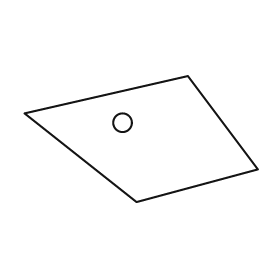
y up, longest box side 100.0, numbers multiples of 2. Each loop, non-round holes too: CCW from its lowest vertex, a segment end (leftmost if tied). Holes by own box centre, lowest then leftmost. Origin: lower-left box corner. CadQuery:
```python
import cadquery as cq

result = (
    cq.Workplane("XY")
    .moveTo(48.0, 0.0)
    .lineTo(100.0, 14.0)
    .lineTo(70.0, 54.0)
    .lineTo(0.0, 38.0)
    .close()
    .moveTo(42.0, 34.0)
    .circle(4.0)
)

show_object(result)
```